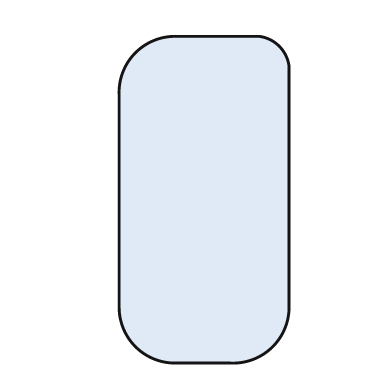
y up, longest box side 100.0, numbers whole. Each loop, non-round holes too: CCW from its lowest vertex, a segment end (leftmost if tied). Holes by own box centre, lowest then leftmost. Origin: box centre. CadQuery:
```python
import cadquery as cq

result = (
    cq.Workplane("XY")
    .moveTo(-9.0, -50.0)
    .lineTo(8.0, -50.0)
    .threePointArc((21.0, -45.0), (26.0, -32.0))
    .lineTo(26.0, 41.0)
    .threePointArc((23.0, 47.0), (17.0, 50.0))
    .lineTo(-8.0, 50.0)
    .threePointArc((-21.0, 45.0), (-26.0, 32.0))
    .lineTo(-26.0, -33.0)
    .threePointArc((-21.0, -45.0), (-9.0, -50.0))
    .close()
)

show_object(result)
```